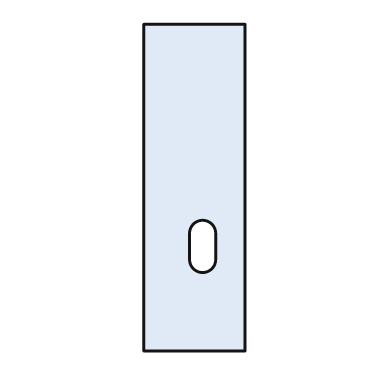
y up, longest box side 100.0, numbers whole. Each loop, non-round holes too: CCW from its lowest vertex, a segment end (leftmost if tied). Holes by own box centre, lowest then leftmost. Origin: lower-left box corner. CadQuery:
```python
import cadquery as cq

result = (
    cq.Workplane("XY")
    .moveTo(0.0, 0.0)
    .lineTo(31.0, 0.0)
    .lineTo(31.0, 100.0)
    .lineTo(0.0, 100.0)
    .close()
    .moveTo(14.0, 28.0)
    .threePointArc((18.0, 24.0), (22.0, 28.0))
    .lineTo(22.0, 36.0)
    .threePointArc((18.0, 40.0), (14.0, 36.0))
    .close()
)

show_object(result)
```